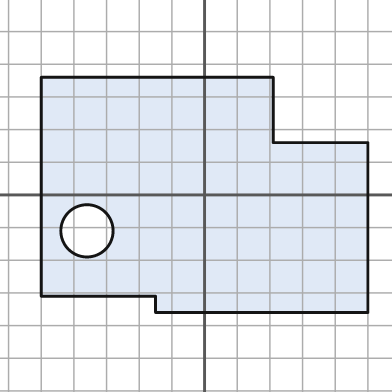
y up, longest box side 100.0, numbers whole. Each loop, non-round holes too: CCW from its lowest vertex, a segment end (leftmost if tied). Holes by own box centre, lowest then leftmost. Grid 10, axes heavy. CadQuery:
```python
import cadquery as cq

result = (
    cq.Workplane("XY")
    .moveTo(-15.0, -36.0)
    .lineTo(50.0, -36.0)
    .lineTo(50.0, 16.0)
    .lineTo(21.0, 16.0)
    .lineTo(21.0, 36.0)
    .lineTo(-50.0, 36.0)
    .lineTo(-50.0, -31.0)
    .lineTo(-15.0, -31.0)
    .close()
    .moveTo(-36.0, -11.0)
    .circle(8.0)
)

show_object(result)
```